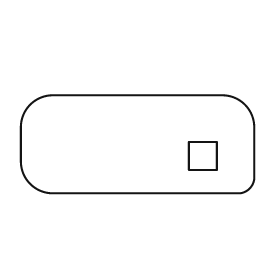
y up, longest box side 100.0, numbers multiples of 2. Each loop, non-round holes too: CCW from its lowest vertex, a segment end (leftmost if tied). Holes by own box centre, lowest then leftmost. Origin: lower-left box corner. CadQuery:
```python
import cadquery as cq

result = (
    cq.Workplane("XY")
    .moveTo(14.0, 0.0)
    .lineTo(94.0, 0.0)
    .threePointArc((98.0, 2.0), (100.0, 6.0))
    .lineTo(100.0, 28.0)
    .threePointArc((96.0, 38.0), (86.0, 42.0))
    .lineTo(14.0, 42.0)
    .threePointArc((4.0, 38.0), (0.0, 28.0))
    .lineTo(0.0, 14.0)
    .threePointArc((4.0, 4.0), (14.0, 0.0))
    .close()
    .moveTo(72.0, 10.0)
    .lineTo(84.0, 10.0)
    .lineTo(84.0, 22.0)
    .lineTo(72.0, 22.0)
    .close()
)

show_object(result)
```